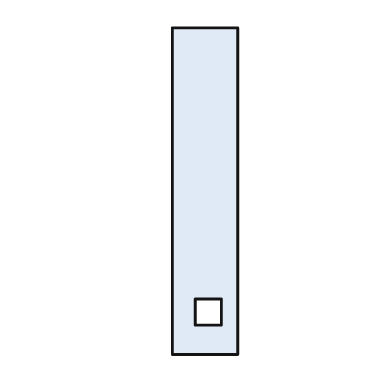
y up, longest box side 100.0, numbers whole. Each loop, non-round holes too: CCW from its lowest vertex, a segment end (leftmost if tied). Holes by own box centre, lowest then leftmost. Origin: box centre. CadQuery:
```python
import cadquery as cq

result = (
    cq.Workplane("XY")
    .moveTo(-10.0, -50.0)
    .lineTo(10.0, -50.0)
    .lineTo(10.0, 50.0)
    .lineTo(-10.0, 50.0)
    .close()
    .moveTo(-3.0, -41.0)
    .lineTo(5.0, -41.0)
    .lineTo(5.0, -33.0)
    .lineTo(-3.0, -33.0)
    .close()
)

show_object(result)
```